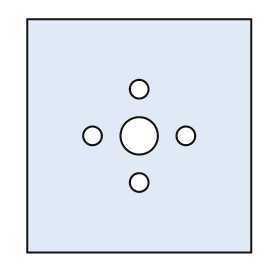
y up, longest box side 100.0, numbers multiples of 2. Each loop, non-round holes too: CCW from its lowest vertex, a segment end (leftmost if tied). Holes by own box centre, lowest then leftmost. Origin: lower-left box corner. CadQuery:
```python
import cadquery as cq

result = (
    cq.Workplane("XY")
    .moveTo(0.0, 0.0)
    .lineTo(96.0, 0.0)
    .lineTo(96.0, 100.0)
    .lineTo(0.0, 100.0)
    .close()
    .moveTo(48.0, 30.0)
    .circle(4.0)
    .moveTo(28.0, 50.0)
    .circle(4.0)
    .moveTo(48.0, 50.0)
    .circle(8.0)
    .moveTo(68.0, 50.0)
    .circle(4.0)
    .moveTo(48.0, 70.0)
    .circle(4.0)
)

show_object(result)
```